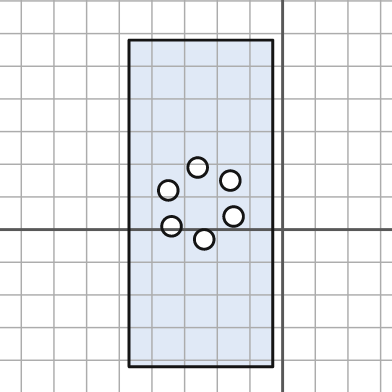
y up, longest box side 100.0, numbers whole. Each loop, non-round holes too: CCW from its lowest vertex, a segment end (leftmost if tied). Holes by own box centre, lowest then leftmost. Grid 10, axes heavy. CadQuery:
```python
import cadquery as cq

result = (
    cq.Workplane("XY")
    .moveTo(-47.0, -42.0)
    .lineTo(-3.0, -42.0)
    .lineTo(-3.0, 58.0)
    .lineTo(-47.0, 58.0)
    .close()
    .moveTo(-24.0, -3.0)
    .circle(3.0)
    .moveTo(-34.0, 1.0)
    .circle(3.0)
    .moveTo(-15.0, 4.0)
    .circle(3.0)
    .moveTo(-35.0, 12.0)
    .circle(3.0)
    .moveTo(-16.0, 15.0)
    .circle(3.0)
    .moveTo(-26.0, 19.0)
    .circle(3.0)
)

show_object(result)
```